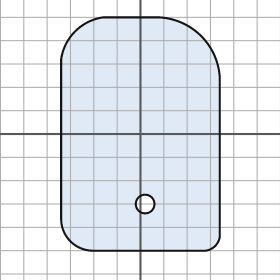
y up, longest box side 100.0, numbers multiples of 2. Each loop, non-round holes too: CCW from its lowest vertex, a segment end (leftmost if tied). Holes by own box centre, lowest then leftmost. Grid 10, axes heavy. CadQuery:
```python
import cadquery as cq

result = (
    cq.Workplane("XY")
    .moveTo(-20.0, -50.0)
    .lineTo(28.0, -50.0)
    .threePointArc((32.0, -48.0), (34.0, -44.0))
    .lineTo(34.0, 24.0)
    .threePointArc((26.0, 42.0), (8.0, 50.0))
    .lineTo(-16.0, 50.0)
    .threePointArc((-28.0, 44.0), (-34.0, 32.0))
    .lineTo(-34.0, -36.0)
    .threePointArc((-30.0, -46.0), (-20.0, -50.0))
    .close()
    .moveTo(2.0, -30.0)
    .circle(4.0)
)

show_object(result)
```